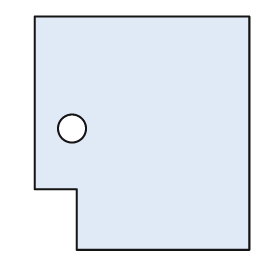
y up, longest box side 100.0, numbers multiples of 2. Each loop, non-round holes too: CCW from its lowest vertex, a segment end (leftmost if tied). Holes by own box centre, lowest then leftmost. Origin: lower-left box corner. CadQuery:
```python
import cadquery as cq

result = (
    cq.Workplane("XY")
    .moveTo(18.0, 0.0)
    .lineTo(92.0, 0.0)
    .lineTo(92.0, 100.0)
    .lineTo(0.0, 100.0)
    .lineTo(0.0, 26.0)
    .lineTo(18.0, 26.0)
    .close()
    .moveTo(16.0, 52.0)
    .circle(6.0)
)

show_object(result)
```